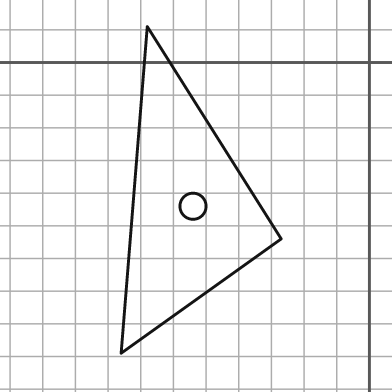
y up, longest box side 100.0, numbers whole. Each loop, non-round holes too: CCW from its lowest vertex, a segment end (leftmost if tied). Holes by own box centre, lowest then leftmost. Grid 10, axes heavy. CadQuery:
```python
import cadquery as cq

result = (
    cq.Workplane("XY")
    .moveTo(-76.0, -89.0)
    .lineTo(-27.0, -54.0)
    .lineTo(-68.0, 11.0)
    .close()
    .moveTo(-54.0, -44.0)
    .circle(4.0)
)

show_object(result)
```